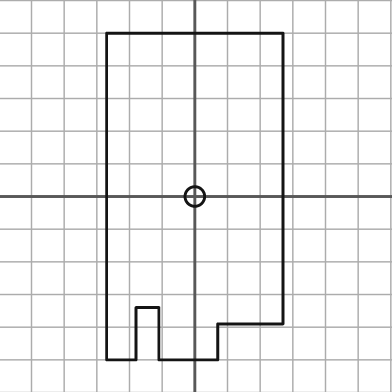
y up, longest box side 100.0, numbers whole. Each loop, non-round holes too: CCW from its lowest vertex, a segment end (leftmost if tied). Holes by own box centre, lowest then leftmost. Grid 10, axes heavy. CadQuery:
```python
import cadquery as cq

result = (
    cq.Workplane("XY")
    .moveTo(-27.0, -50.0)
    .lineTo(-18.0, -50.0)
    .lineTo(-18.0, -34.0)
    .lineTo(-11.0, -34.0)
    .lineTo(-11.0, -50.0)
    .lineTo(7.0, -50.0)
    .lineTo(7.0, -39.0)
    .lineTo(27.0, -39.0)
    .lineTo(27.0, 50.0)
    .lineTo(-27.0, 50.0)
    .close()
    .moveTo(0.0, 0.0)
    .circle(3.0)
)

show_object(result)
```